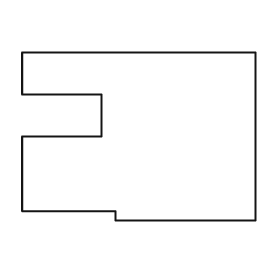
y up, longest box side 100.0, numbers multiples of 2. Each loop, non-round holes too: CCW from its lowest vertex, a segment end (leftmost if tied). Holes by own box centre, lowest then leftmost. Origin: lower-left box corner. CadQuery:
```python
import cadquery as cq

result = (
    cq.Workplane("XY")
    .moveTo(40.0, 0.0)
    .lineTo(100.0, 0.0)
    .lineTo(100.0, 72.0)
    .lineTo(0.0, 72.0)
    .lineTo(0.0, 54.0)
    .lineTo(34.0, 54.0)
    .lineTo(34.0, 36.0)
    .lineTo(0.0, 36.0)
    .lineTo(0.0, 4.0)
    .lineTo(40.0, 4.0)
    .close()
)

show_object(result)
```